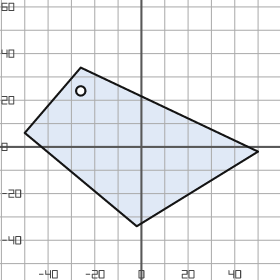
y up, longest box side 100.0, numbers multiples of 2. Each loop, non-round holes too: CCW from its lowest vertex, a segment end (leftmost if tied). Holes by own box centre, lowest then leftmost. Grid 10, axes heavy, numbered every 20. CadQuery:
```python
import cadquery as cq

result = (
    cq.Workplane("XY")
    .moveTo(-2.0, -34.0)
    .lineTo(50.0, -2.0)
    .lineTo(-26.0, 34.0)
    .lineTo(-50.0, 6.0)
    .close()
    .moveTo(-26.0, 24.0)
    .circle(2.0)
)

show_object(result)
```